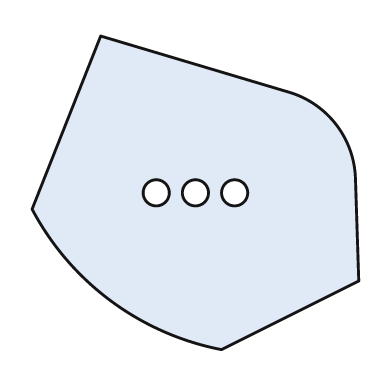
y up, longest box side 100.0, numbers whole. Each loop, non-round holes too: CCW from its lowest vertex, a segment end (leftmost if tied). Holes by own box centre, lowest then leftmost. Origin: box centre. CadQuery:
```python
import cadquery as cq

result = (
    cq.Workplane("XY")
    .moveTo(8.0, -48.0)
    .lineTo(50.0, -27.0)
    .lineTo(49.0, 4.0)
    .threePointArc((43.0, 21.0), (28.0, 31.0))
    .lineTo(-29.0, 48.0)
    .lineTo(-50.0, -5.0)
    .threePointArc((-26.0, -33.0), (8.0, -48.0))
    .close()
    .moveTo(-12.0, 0.0)
    .circle(4.0)
    .moveTo(0.0, 0.0)
    .circle(4.0)
    .moveTo(12.0, 0.0)
    .circle(4.0)
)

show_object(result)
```